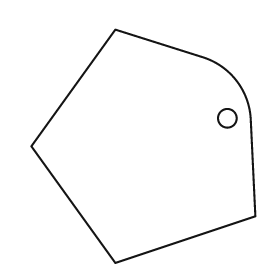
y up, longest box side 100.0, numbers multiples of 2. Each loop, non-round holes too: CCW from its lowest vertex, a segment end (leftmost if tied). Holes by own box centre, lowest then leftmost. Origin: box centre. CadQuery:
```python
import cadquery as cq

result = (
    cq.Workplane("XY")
    .moveTo(-12.0, -50.0)
    .lineTo(48.0, -30.0)
    .lineTo(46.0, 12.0)
    .threePointArc((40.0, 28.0), (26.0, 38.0))
    .lineTo(-12.0, 50.0)
    .lineTo(-48.0, 0.0)
    .close()
    .moveTo(36.0, 12.0)
    .circle(4.0)
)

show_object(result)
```